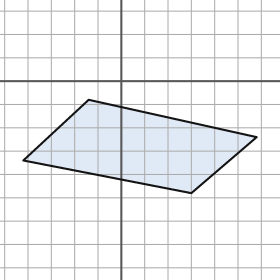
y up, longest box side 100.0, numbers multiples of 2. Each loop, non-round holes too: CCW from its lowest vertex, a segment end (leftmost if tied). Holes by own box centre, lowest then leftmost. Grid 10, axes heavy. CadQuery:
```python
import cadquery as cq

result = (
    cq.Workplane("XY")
    .moveTo(30.0, -48.0)
    .lineTo(58.0, -24.0)
    .lineTo(-14.0, -8.0)
    .lineTo(-42.0, -34.0)
    .close()
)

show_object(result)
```